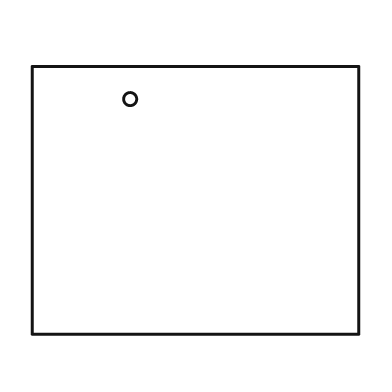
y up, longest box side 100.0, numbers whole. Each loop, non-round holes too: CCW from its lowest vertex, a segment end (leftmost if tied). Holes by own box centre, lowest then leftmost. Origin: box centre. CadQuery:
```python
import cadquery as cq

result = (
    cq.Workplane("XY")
    .moveTo(-50.0, -41.0)
    .lineTo(50.0, -41.0)
    .lineTo(50.0, 41.0)
    .lineTo(-50.0, 41.0)
    .close()
    .moveTo(-20.0, 31.0)
    .circle(2.0)
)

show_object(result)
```